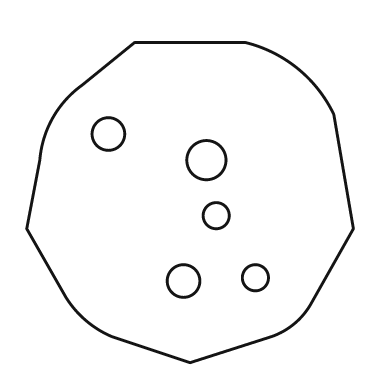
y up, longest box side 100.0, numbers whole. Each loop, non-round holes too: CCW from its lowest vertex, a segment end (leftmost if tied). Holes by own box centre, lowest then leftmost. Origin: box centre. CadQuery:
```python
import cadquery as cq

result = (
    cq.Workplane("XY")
    .moveTo(0.0, -49.0)
    .lineTo(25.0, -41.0)
    .threePointArc((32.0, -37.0), (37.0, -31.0))
    .lineTo(50.0, -8.0)
    .lineTo(44.0, 27.0)
    .threePointArc((33.0, 41.0), (17.0, 49.0))
    .lineTo(-17.0, 49.0)
    .lineTo(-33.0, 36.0)
    .threePointArc((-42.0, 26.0), (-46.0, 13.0))
    .lineTo(-50.0, -8.0)
    .lineTo(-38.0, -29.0)
    .threePointArc((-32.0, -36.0), (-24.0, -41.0))
    .close()
    .moveTo(-2.0, -24.0)
    .circle(5.0)
    .moveTo(20.0, -23.0)
    .circle(4.0)
    .moveTo(8.0, -4.0)
    .circle(4.0)
    .moveTo(5.0, 13.0)
    .circle(6.0)
    .moveTo(-25.0, 21.0)
    .circle(5.0)
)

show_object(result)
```